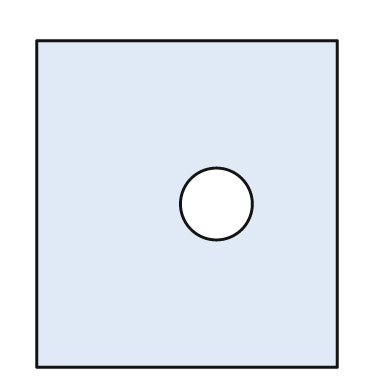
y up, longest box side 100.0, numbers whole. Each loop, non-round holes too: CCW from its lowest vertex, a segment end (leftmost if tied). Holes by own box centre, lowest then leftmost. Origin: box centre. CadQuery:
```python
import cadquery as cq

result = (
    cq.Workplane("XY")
    .moveTo(-46.0, -50.0)
    .lineTo(46.0, -50.0)
    .lineTo(46.0, 50.0)
    .lineTo(-46.0, 50.0)
    .close()
    .moveTo(9.0, 0.0)
    .circle(11.0)
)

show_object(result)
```